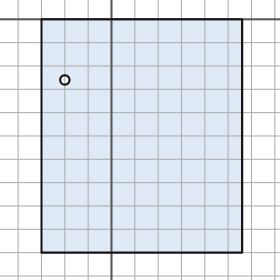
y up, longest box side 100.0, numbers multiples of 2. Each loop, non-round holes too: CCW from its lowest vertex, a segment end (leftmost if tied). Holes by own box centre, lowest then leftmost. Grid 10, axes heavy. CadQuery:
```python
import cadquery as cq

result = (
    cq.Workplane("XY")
    .moveTo(-30.0, -100.0)
    .lineTo(56.0, -100.0)
    .lineTo(56.0, 0.0)
    .lineTo(-30.0, 0.0)
    .close()
    .moveTo(-20.0, -26.0)
    .circle(2.0)
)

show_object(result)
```